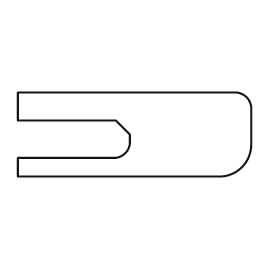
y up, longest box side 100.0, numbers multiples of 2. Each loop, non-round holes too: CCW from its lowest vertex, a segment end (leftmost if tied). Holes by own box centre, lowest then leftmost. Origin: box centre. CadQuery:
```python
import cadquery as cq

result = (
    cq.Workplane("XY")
    .moveTo(-50.0, -18.0)
    .lineTo(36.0, -18.0)
    .threePointArc((46.0, -14.0), (50.0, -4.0))
    .lineTo(50.0, 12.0)
    .threePointArc((48.0, 16.0), (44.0, 18.0))
    .lineTo(-50.0, 18.0)
    .lineTo(-50.0, 6.0)
    .lineTo(-8.0, 6.0)
    .lineTo(-2.0, 0.0)
    .lineTo(-2.0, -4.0)
    .threePointArc((-4.0, -8.0), (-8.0, -10.0))
    .lineTo(-50.0, -10.0)
    .close()
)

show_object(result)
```